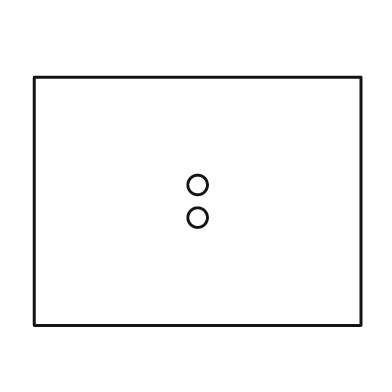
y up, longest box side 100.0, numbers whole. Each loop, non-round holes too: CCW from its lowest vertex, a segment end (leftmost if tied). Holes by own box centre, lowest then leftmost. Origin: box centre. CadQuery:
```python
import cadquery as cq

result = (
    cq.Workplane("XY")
    .moveTo(-50.0, -38.0)
    .lineTo(50.0, -38.0)
    .lineTo(50.0, 38.0)
    .lineTo(-50.0, 38.0)
    .close()
    .moveTo(0.0, -5.0)
    .circle(3.0)
    .moveTo(0.0, 5.0)
    .circle(3.0)
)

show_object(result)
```